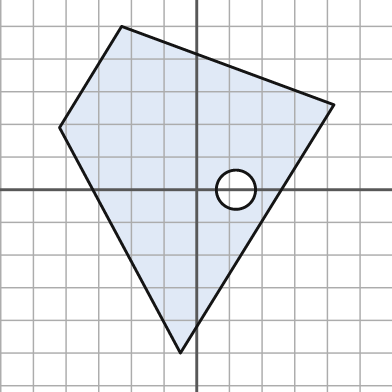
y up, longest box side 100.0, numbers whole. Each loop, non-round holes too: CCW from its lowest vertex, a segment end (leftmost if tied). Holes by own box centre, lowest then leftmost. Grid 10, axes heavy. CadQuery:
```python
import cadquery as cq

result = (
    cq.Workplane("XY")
    .moveTo(-5.0, -50.0)
    .lineTo(42.0, 26.0)
    .lineTo(-23.0, 50.0)
    .lineTo(-42.0, 19.0)
    .close()
    .moveTo(12.0, 0.0)
    .circle(6.0)
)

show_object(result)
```